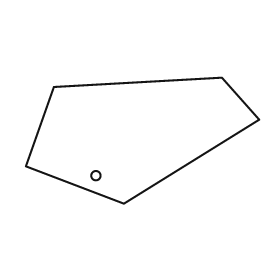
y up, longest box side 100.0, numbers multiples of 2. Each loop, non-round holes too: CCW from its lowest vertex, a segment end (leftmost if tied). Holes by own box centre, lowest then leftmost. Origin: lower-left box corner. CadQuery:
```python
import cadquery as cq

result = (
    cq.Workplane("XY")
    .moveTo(42.0, 0.0)
    .lineTo(100.0, 36.0)
    .lineTo(84.0, 54.0)
    .lineTo(12.0, 50.0)
    .lineTo(0.0, 16.0)
    .close()
    .moveTo(30.0, 12.0)
    .circle(2.0)
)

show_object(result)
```